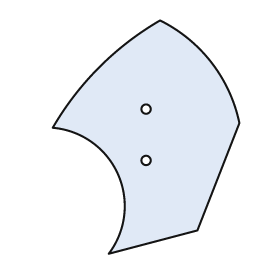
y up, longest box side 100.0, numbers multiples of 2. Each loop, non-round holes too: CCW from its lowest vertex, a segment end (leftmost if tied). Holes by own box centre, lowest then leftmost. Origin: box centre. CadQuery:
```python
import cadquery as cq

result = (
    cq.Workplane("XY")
    .moveTo(-16.0, -50.0)
    .lineTo(22.0, -40.0)
    .lineTo(40.0, 6.0)
    .threePointArc((28.0, 32.0), (6.0, 50.0))
    .threePointArc((-20.0, 30.0), (-40.0, 4.0))
    .threePointArc((-12.0, -16.0), (-16.0, -50.0))
    .close()
    .moveTo(0.0, -10.0)
    .circle(2.0)
    .moveTo(0.0, 12.0)
    .circle(2.0)
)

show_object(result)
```